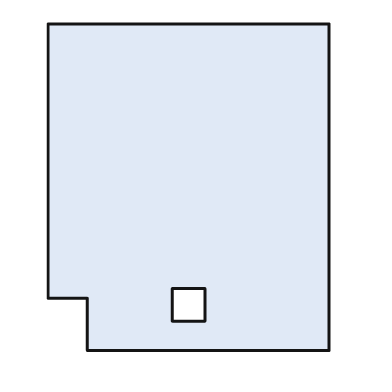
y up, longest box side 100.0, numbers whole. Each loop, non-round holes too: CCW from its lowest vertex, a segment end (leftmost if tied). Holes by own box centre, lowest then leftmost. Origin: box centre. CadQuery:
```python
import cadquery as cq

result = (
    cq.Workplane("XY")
    .moveTo(-31.0, -50.0)
    .lineTo(43.0, -50.0)
    .lineTo(43.0, 50.0)
    .lineTo(-43.0, 50.0)
    .lineTo(-43.0, -34.0)
    .lineTo(-31.0, -34.0)
    .close()
    .moveTo(-5.0, -41.0)
    .lineTo(5.0, -41.0)
    .lineTo(5.0, -31.0)
    .lineTo(-5.0, -31.0)
    .close()
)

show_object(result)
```